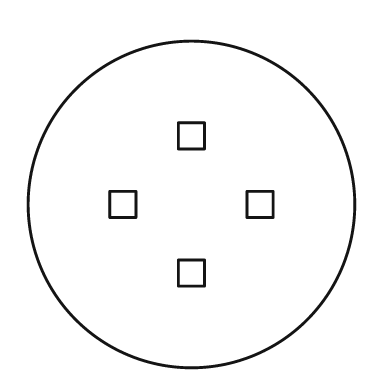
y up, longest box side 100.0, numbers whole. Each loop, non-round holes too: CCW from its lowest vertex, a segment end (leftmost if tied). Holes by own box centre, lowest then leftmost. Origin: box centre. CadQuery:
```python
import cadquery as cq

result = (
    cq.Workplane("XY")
    .moveTo(0.0, 0.0)
    .circle(50.0)
    .moveTo(-4.0, -25.0)
    .lineTo(4.0, -25.0)
    .lineTo(4.0, -17.0)
    .lineTo(-4.0, -17.0)
    .close()
    .moveTo(-25.0, -4.0)
    .lineTo(-17.0, -4.0)
    .lineTo(-17.0, 4.0)
    .lineTo(-25.0, 4.0)
    .close()
    .moveTo(17.0, -4.0)
    .lineTo(25.0, -4.0)
    .lineTo(25.0, 4.0)
    .lineTo(17.0, 4.0)
    .close()
    .moveTo(-4.0, 17.0)
    .lineTo(4.0, 17.0)
    .lineTo(4.0, 25.0)
    .lineTo(-4.0, 25.0)
    .close()
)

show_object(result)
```